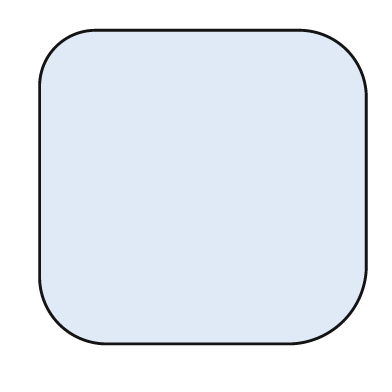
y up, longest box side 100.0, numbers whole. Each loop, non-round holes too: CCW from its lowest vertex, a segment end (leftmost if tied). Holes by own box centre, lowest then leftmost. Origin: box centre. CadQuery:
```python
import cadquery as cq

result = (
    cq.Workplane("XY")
    .moveTo(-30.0, -48.0)
    .lineTo(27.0, -48.0)
    .threePointArc((43.0, -41.0), (50.0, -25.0))
    .lineTo(50.0, 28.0)
    .threePointArc((44.0, 42.0), (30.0, 48.0))
    .lineTo(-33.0, 48.0)
    .threePointArc((-45.0, 43.0), (-50.0, 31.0))
    .lineTo(-50.0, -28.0)
    .threePointArc((-44.0, -42.0), (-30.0, -48.0))
    .close()
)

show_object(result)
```